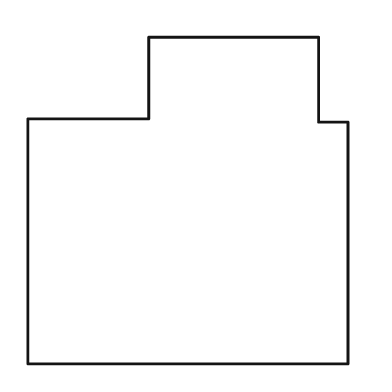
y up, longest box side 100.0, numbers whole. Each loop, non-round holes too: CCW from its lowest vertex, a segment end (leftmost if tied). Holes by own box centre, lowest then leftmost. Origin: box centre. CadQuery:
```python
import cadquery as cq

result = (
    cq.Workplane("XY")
    .moveTo(-49.0, -50.0)
    .lineTo(49.0, -50.0)
    .lineTo(49.0, 24.0)
    .lineTo(40.0, 24.0)
    .lineTo(40.0, 50.0)
    .lineTo(-12.0, 50.0)
    .lineTo(-12.0, 25.0)
    .lineTo(-49.0, 25.0)
    .close()
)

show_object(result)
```